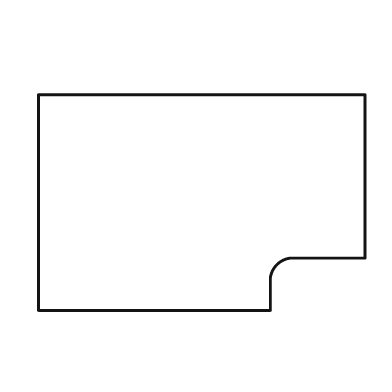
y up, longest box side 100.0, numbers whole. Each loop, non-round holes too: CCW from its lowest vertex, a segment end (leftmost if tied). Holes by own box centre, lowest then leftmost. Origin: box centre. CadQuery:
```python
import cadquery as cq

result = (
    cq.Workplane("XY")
    .moveTo(-50.0, -33.0)
    .lineTo(21.0, -33.0)
    .lineTo(21.0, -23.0)
    .threePointArc((23.0, -19.0), (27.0, -17.0))
    .lineTo(50.0, -17.0)
    .lineTo(50.0, 33.0)
    .lineTo(-50.0, 33.0)
    .close()
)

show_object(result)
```